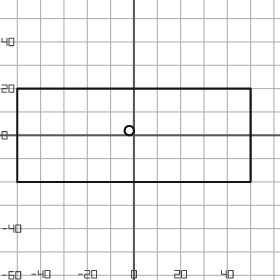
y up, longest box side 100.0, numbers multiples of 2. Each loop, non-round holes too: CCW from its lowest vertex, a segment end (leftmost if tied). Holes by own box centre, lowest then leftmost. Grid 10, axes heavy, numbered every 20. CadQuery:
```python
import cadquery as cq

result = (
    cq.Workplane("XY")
    .moveTo(-50.0, -20.0)
    .lineTo(50.0, -20.0)
    .lineTo(50.0, 20.0)
    .lineTo(-50.0, 20.0)
    .close()
    .moveTo(-2.0, 2.0)
    .circle(2.0)
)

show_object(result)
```